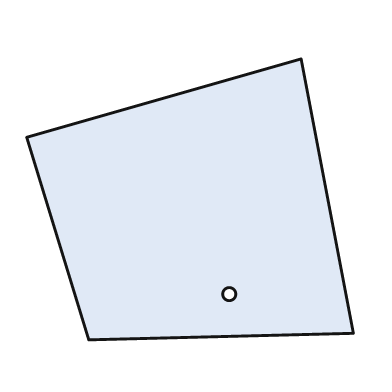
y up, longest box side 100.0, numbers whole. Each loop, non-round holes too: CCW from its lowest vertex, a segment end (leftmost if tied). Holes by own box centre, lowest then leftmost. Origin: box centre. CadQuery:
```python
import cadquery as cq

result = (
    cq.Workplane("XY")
    .moveTo(-31.0, -43.0)
    .lineTo(50.0, -41.0)
    .lineTo(34.0, 43.0)
    .lineTo(-50.0, 19.0)
    .close()
    .moveTo(12.0, -29.0)
    .circle(2.0)
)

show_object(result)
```